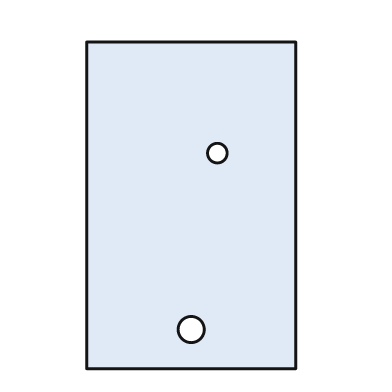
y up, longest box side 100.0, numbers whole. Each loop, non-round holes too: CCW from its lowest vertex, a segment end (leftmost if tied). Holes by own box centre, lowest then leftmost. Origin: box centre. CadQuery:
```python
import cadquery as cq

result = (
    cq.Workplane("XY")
    .moveTo(-32.0, -50.0)
    .lineTo(32.0, -50.0)
    .lineTo(32.0, 50.0)
    .lineTo(-32.0, 50.0)
    .close()
    .moveTo(0.0, -38.0)
    .circle(4.0)
    .moveTo(8.0, 16.0)
    .circle(3.0)
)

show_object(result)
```